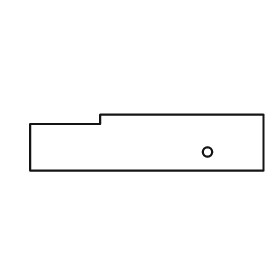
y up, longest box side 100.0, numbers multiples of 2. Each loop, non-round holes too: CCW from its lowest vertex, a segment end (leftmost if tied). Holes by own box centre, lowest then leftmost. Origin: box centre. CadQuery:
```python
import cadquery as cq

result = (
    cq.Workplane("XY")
    .moveTo(-50.0, -12.0)
    .lineTo(50.0, -12.0)
    .lineTo(50.0, 12.0)
    .lineTo(-20.0, 12.0)
    .lineTo(-20.0, 8.0)
    .lineTo(-50.0, 8.0)
    .close()
    .moveTo(26.0, -4.0)
    .circle(2.0)
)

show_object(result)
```